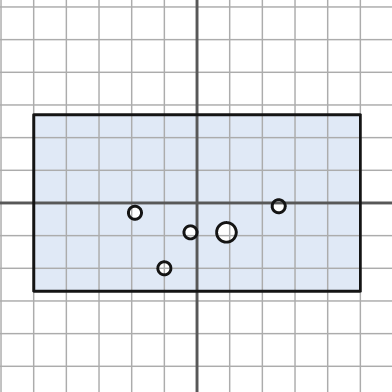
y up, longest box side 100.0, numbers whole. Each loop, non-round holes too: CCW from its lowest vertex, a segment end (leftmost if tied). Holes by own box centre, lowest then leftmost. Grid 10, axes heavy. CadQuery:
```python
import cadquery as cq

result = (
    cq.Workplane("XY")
    .moveTo(-50.0, -27.0)
    .lineTo(50.0, -27.0)
    .lineTo(50.0, 27.0)
    .lineTo(-50.0, 27.0)
    .close()
    .moveTo(-10.0, -20.0)
    .circle(2.0)
    .moveTo(-2.0, -9.0)
    .circle(2.0)
    .moveTo(9.0, -9.0)
    .circle(3.0)
    .moveTo(-19.0, -3.0)
    .circle(2.0)
    .moveTo(25.0, -1.0)
    .circle(2.0)
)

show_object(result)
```